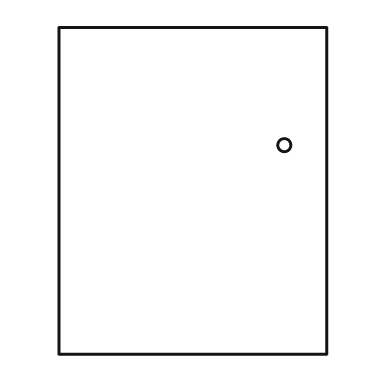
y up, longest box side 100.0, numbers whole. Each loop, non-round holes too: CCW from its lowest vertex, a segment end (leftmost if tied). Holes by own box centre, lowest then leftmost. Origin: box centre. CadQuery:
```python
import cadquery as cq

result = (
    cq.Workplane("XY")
    .moveTo(-41.0, -50.0)
    .lineTo(41.0, -50.0)
    .lineTo(41.0, 50.0)
    .lineTo(-41.0, 50.0)
    .close()
    .moveTo(28.0, 14.0)
    .circle(2.0)
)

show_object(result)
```